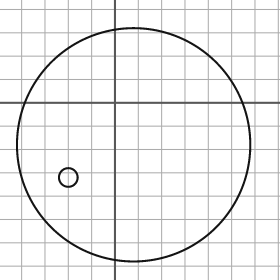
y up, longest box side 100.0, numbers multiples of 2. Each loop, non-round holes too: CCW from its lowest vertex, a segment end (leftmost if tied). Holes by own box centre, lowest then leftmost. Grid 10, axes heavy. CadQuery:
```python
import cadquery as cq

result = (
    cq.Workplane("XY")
    .moveTo(8.0, -18.0)
    .circle(50.0)
    .moveTo(-20.0, -32.0)
    .circle(4.0)
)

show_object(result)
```